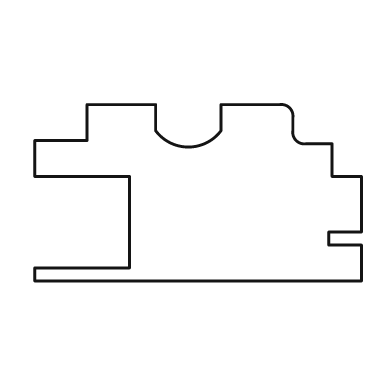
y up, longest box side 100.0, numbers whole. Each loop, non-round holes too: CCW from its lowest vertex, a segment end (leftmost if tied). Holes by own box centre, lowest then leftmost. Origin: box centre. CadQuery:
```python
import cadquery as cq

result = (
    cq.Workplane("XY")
    .moveTo(-50.0, -27.0)
    .lineTo(50.0, -27.0)
    .lineTo(50.0, -16.0)
    .lineTo(40.0, -16.0)
    .lineTo(40.0, -12.0)
    .lineTo(50.0, -12.0)
    .lineTo(50.0, 5.0)
    .lineTo(41.0, 5.0)
    .lineTo(41.0, 15.0)
    .lineTo(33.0, 15.0)
    .threePointArc((30.0, 16.0), (29.0, 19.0))
    .lineTo(29.0, 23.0)
    .threePointArc((28.0, 26.0), (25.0, 27.0))
    .lineTo(7.0, 27.0)
    .lineTo(7.0, 19.0)
    .threePointArc((-3.0, 14.0), (-13.0, 19.0))
    .lineTo(-13.0, 27.0)
    .lineTo(-34.0, 27.0)
    .lineTo(-34.0, 16.0)
    .lineTo(-50.0, 16.0)
    .lineTo(-50.0, 5.0)
    .lineTo(-21.0, 5.0)
    .lineTo(-21.0, -23.0)
    .lineTo(-50.0, -23.0)
    .close()
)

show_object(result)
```